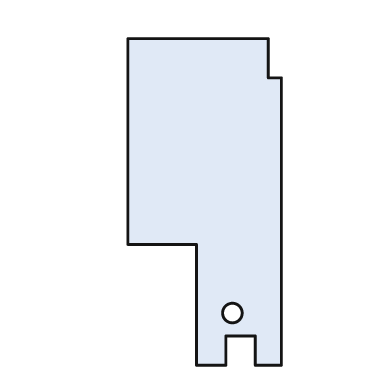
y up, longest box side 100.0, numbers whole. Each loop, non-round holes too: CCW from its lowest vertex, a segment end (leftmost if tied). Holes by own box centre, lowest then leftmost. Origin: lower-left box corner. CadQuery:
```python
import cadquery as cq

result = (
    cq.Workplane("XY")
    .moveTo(21.0, 0.0)
    .lineTo(30.0, 0.0)
    .lineTo(30.0, 9.0)
    .lineTo(39.0, 9.0)
    .lineTo(39.0, 0.0)
    .lineTo(47.0, 0.0)
    .lineTo(47.0, 88.0)
    .lineTo(43.0, 88.0)
    .lineTo(43.0, 100.0)
    .lineTo(0.0, 100.0)
    .lineTo(0.0, 37.0)
    .lineTo(21.0, 37.0)
    .close()
    .moveTo(32.0, 16.0)
    .circle(3.0)
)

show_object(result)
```